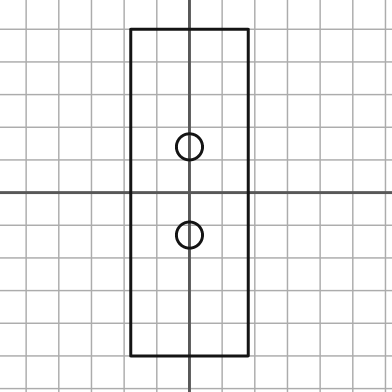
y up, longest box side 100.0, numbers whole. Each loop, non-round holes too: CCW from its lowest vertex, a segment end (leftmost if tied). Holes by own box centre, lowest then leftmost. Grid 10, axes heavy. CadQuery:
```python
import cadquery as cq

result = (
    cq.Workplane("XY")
    .moveTo(-18.0, -50.0)
    .lineTo(18.0, -50.0)
    .lineTo(18.0, 50.0)
    .lineTo(-18.0, 50.0)
    .close()
    .moveTo(0.0, -13.0)
    .circle(4.0)
    .moveTo(0.0, 14.0)
    .circle(4.0)
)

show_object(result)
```